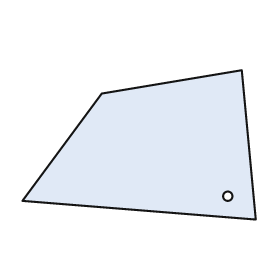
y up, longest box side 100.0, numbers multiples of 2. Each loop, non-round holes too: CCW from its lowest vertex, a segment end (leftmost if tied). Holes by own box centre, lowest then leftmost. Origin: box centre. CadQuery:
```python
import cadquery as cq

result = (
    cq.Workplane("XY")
    .moveTo(50.0, -32.0)
    .lineTo(44.0, 32.0)
    .lineTo(-16.0, 22.0)
    .lineTo(-50.0, -24.0)
    .close()
    .moveTo(38.0, -22.0)
    .circle(2.0)
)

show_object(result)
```